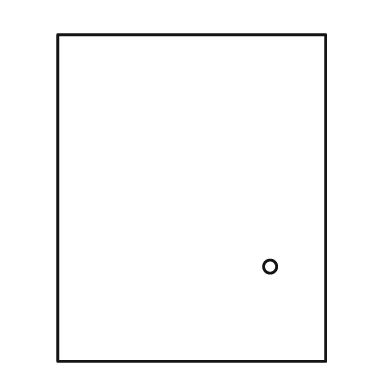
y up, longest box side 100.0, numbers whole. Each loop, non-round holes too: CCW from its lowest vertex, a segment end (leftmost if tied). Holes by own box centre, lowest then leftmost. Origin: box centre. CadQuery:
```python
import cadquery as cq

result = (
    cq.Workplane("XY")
    .moveTo(-41.0, -50.0)
    .lineTo(41.0, -50.0)
    .lineTo(41.0, 50.0)
    .lineTo(-41.0, 50.0)
    .close()
    .moveTo(24.0, -21.0)
    .circle(2.0)
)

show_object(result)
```